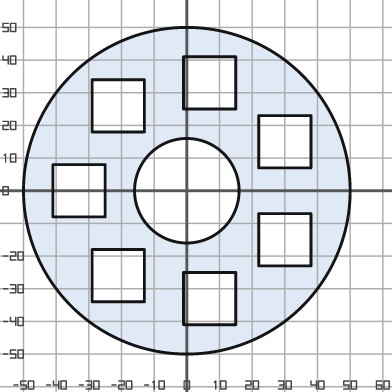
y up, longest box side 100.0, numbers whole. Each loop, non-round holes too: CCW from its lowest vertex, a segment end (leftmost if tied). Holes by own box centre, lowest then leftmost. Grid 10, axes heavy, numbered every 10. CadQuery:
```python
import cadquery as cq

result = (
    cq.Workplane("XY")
    .moveTo(0.0, 0.0)
    .circle(50.0)
    .moveTo(-1.0, -41.0)
    .lineTo(15.0, -41.0)
    .lineTo(15.0, -25.0)
    .lineTo(-1.0, -25.0)
    .close()
    .moveTo(-29.0, -34.0)
    .lineTo(-13.0, -34.0)
    .lineTo(-13.0, -18.0)
    .lineTo(-29.0, -18.0)
    .close()
    .moveTo(22.0, -23.0)
    .lineTo(38.0, -23.0)
    .lineTo(38.0, -7.0)
    .lineTo(22.0, -7.0)
    .close()
    .moveTo(-41.0, -8.0)
    .lineTo(-25.0, -8.0)
    .lineTo(-25.0, 8.0)
    .lineTo(-41.0, 8.0)
    .close()
    .moveTo(0.0, 0.0)
    .circle(16.0)
    .moveTo(22.0, 7.0)
    .lineTo(38.0, 7.0)
    .lineTo(38.0, 23.0)
    .lineTo(22.0, 23.0)
    .close()
    .moveTo(-29.0, 18.0)
    .lineTo(-13.0, 18.0)
    .lineTo(-13.0, 34.0)
    .lineTo(-29.0, 34.0)
    .close()
    .moveTo(-1.0, 25.0)
    .lineTo(15.0, 25.0)
    .lineTo(15.0, 41.0)
    .lineTo(-1.0, 41.0)
    .close()
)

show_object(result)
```